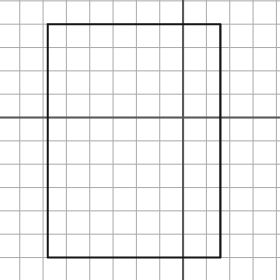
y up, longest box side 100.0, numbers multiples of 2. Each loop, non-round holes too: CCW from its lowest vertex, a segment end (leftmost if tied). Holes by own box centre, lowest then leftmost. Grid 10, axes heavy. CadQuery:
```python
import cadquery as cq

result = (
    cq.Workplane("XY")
    .moveTo(-58.0, -60.0)
    .lineTo(16.0, -60.0)
    .lineTo(16.0, 40.0)
    .lineTo(-58.0, 40.0)
    .close()
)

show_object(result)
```